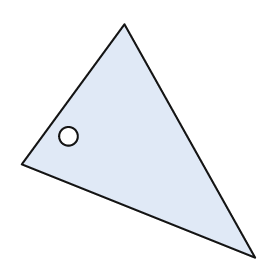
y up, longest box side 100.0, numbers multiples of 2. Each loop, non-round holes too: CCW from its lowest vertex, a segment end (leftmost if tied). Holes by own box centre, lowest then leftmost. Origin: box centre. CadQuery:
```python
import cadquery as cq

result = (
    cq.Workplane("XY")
    .moveTo(50.0, -50.0)
    .lineTo(-6.0, 50.0)
    .lineTo(-50.0, -10.0)
    .close()
    .moveTo(-30.0, 2.0)
    .circle(4.0)
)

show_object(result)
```